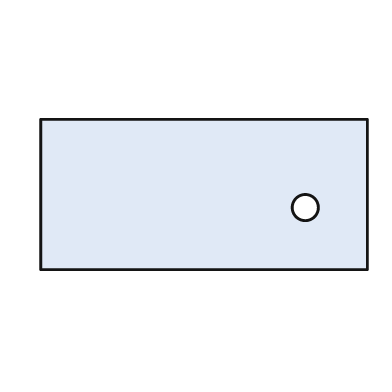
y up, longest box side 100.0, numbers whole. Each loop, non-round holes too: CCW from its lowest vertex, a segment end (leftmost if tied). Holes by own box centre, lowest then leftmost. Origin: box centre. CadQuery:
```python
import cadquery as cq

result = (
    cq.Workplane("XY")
    .moveTo(-50.0, -23.0)
    .lineTo(50.0, -23.0)
    .lineTo(50.0, 23.0)
    .lineTo(-50.0, 23.0)
    .close()
    .moveTo(31.0, -4.0)
    .circle(4.0)
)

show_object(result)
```